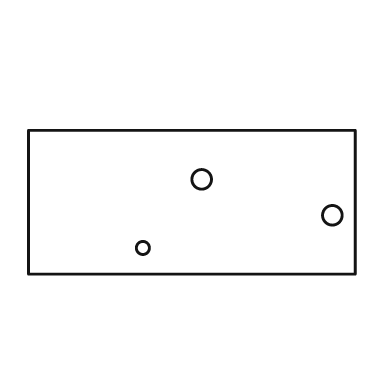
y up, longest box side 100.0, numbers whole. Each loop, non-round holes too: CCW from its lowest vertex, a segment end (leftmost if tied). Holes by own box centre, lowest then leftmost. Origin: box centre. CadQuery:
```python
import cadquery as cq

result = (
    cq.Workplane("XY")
    .moveTo(-50.0, -22.0)
    .lineTo(50.0, -22.0)
    .lineTo(50.0, 22.0)
    .lineTo(-50.0, 22.0)
    .close()
    .moveTo(-15.0, -14.0)
    .circle(2.0)
    .moveTo(43.0, -4.0)
    .circle(3.0)
    .moveTo(3.0, 7.0)
    .circle(3.0)
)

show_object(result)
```